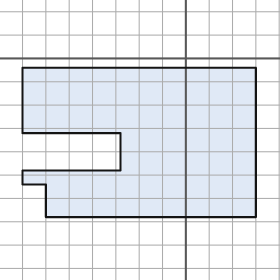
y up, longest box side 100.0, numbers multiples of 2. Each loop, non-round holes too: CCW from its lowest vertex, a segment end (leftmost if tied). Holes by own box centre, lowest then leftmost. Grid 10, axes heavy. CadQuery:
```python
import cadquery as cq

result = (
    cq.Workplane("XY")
    .moveTo(-60.0, -68.0)
    .lineTo(30.0, -68.0)
    .lineTo(30.0, -4.0)
    .lineTo(-70.0, -4.0)
    .lineTo(-70.0, -32.0)
    .lineTo(-28.0, -32.0)
    .lineTo(-28.0, -48.0)
    .lineTo(-70.0, -48.0)
    .lineTo(-70.0, -54.0)
    .lineTo(-60.0, -54.0)
    .close()
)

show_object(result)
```